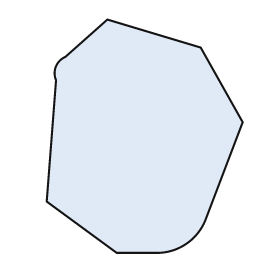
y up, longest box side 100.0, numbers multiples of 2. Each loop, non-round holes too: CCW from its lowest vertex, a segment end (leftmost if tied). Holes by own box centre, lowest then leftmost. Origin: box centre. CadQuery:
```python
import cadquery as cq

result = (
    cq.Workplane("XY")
    .moveTo(-12.0, -50.0)
    .lineTo(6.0, -50.0)
    .threePointArc((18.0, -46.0), (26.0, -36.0))
    .lineTo(42.0, 6.0)
    .lineTo(24.0, 38.0)
    .lineTo(-16.0, 50.0)
    .lineTo(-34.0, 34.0)
    .threePointArc((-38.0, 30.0), (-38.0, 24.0))
    .lineTo(-42.0, -28.0)
    .close()
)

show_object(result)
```